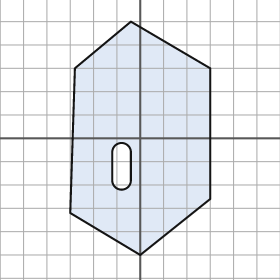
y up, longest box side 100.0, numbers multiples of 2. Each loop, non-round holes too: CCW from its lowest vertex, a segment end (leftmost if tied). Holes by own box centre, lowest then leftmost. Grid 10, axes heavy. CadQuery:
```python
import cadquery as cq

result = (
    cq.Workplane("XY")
    .moveTo(0.0, -50.0)
    .lineTo(30.0, -26.0)
    .lineTo(30.0, 30.0)
    .lineTo(-4.0, 50.0)
    .lineTo(-28.0, 30.0)
    .lineTo(-30.0, -32.0)
    .close()
    .moveTo(-12.0, -18.0)
    .threePointArc((-8.0, -22.0), (-4.0, -18.0))
    .lineTo(-4.0, -6.0)
    .threePointArc((-8.0, -2.0), (-12.0, -6.0))
    .close()
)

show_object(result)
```